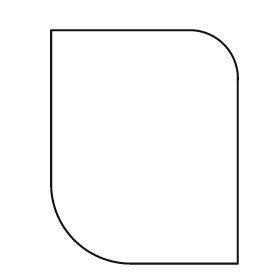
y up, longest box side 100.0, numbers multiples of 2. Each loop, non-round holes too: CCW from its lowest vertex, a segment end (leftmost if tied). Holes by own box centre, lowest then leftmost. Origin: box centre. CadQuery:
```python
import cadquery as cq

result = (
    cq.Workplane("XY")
    .moveTo(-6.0, -50.0)
    .lineTo(40.0, -50.0)
    .lineTo(40.0, 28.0)
    .threePointArc((34.0, 44.0), (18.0, 50.0))
    .lineTo(-40.0, 50.0)
    .lineTo(-40.0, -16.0)
    .threePointArc((-30.0, -40.0), (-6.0, -50.0))
    .close()
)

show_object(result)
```